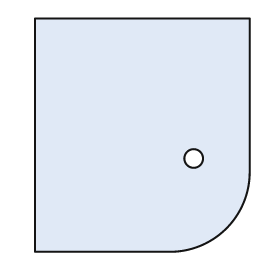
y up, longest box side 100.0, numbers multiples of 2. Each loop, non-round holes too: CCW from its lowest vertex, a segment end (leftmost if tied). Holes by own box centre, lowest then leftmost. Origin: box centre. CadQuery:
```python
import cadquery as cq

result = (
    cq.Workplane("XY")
    .moveTo(-46.0, -50.0)
    .lineTo(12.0, -50.0)
    .threePointArc((36.0, -40.0), (46.0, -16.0))
    .lineTo(46.0, 50.0)
    .lineTo(-46.0, 50.0)
    .close()
    .moveTo(22.0, -10.0)
    .circle(4.0)
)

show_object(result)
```